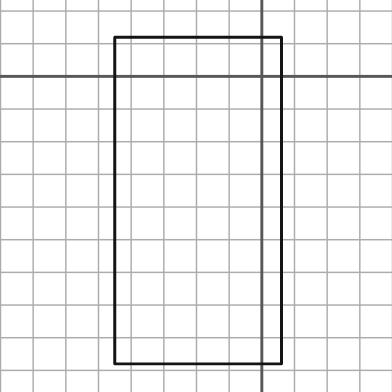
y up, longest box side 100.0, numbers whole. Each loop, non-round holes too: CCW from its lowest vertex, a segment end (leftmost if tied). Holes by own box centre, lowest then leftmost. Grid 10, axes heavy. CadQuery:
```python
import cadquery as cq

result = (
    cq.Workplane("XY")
    .moveTo(-45.0, -88.0)
    .lineTo(6.0, -88.0)
    .lineTo(6.0, 12.0)
    .lineTo(-45.0, 12.0)
    .close()
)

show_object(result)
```